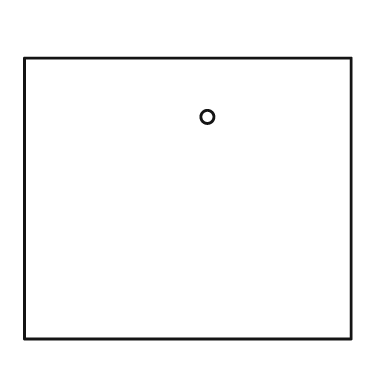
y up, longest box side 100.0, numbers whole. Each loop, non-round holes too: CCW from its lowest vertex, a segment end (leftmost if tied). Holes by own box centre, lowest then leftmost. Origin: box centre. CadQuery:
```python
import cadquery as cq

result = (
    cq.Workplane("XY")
    .moveTo(-50.0, -43.0)
    .lineTo(50.0, -43.0)
    .lineTo(50.0, 43.0)
    .lineTo(-50.0, 43.0)
    .close()
    .moveTo(6.0, 25.0)
    .circle(2.0)
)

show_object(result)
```